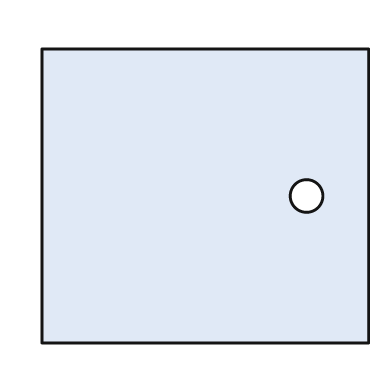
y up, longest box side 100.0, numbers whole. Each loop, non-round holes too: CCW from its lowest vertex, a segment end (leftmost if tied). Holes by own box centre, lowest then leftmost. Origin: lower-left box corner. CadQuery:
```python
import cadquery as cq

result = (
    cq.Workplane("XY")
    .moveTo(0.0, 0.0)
    .lineTo(100.0, 0.0)
    .lineTo(100.0, 90.0)
    .lineTo(0.0, 90.0)
    .close()
    .moveTo(81.0, 45.0)
    .circle(5.0)
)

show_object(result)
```